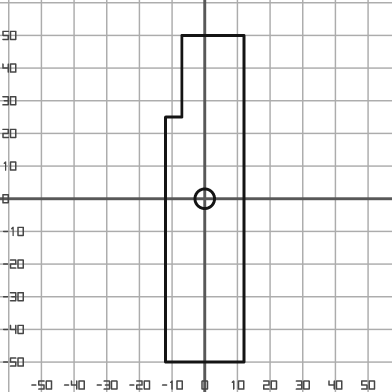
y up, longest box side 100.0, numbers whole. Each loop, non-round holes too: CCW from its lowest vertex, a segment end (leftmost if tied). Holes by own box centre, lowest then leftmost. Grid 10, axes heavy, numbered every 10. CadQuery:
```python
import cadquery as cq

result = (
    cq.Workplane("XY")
    .moveTo(-12.0, -50.0)
    .lineTo(12.0, -50.0)
    .lineTo(12.0, 50.0)
    .lineTo(-7.0, 50.0)
    .lineTo(-7.0, 25.0)
    .lineTo(-12.0, 25.0)
    .close()
    .moveTo(0.0, 0.0)
    .circle(3.0)
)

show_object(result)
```